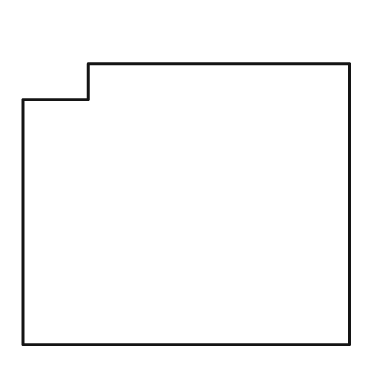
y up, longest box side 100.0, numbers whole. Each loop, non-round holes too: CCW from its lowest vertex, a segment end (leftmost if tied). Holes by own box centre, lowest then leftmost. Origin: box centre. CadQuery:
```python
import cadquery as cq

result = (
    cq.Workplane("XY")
    .moveTo(-50.0, -43.0)
    .lineTo(50.0, -43.0)
    .lineTo(50.0, 43.0)
    .lineTo(-30.0, 43.0)
    .lineTo(-30.0, 32.0)
    .lineTo(-50.0, 32.0)
    .close()
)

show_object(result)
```